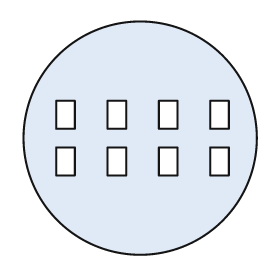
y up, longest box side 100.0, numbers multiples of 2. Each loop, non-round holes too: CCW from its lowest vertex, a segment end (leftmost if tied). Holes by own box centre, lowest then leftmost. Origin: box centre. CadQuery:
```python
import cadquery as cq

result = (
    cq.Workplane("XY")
    .moveTo(0.0, 0.0)
    .circle(50.0)
    .moveTo(-36.0, -16.0)
    .lineTo(-28.0, -16.0)
    .lineTo(-28.0, -4.0)
    .lineTo(-36.0, -4.0)
    .close()
    .moveTo(-14.0, -16.0)
    .lineTo(-6.0, -16.0)
    .lineTo(-6.0, -4.0)
    .lineTo(-14.0, -4.0)
    .close()
    .moveTo(8.0, -16.0)
    .lineTo(16.0, -16.0)
    .lineTo(16.0, -4.0)
    .lineTo(8.0, -4.0)
    .close()
    .moveTo(30.0, -16.0)
    .lineTo(38.0, -16.0)
    .lineTo(38.0, -4.0)
    .lineTo(30.0, -4.0)
    .close()
    .moveTo(-36.0, 4.0)
    .lineTo(-28.0, 4.0)
    .lineTo(-28.0, 16.0)
    .lineTo(-36.0, 16.0)
    .close()
    .moveTo(-14.0, 4.0)
    .lineTo(-6.0, 4.0)
    .lineTo(-6.0, 16.0)
    .lineTo(-14.0, 16.0)
    .close()
    .moveTo(8.0, 4.0)
    .lineTo(16.0, 4.0)
    .lineTo(16.0, 16.0)
    .lineTo(8.0, 16.0)
    .close()
    .moveTo(30.0, 4.0)
    .lineTo(38.0, 4.0)
    .lineTo(38.0, 16.0)
    .lineTo(30.0, 16.0)
    .close()
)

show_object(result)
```